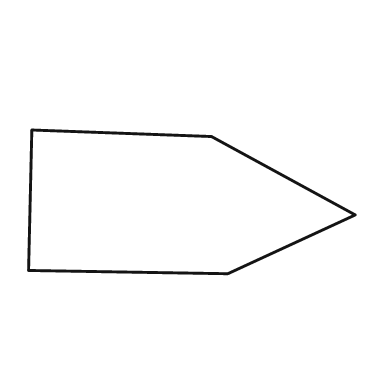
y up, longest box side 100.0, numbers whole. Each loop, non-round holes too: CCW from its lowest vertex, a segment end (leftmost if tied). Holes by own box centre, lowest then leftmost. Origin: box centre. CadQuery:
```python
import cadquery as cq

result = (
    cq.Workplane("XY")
    .moveTo(11.0, -22.0)
    .lineTo(50.0, -4.0)
    .lineTo(6.0, 20.0)
    .lineTo(-49.0, 22.0)
    .lineTo(-50.0, -21.0)
    .close()
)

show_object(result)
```